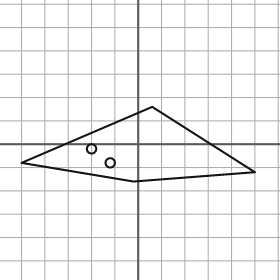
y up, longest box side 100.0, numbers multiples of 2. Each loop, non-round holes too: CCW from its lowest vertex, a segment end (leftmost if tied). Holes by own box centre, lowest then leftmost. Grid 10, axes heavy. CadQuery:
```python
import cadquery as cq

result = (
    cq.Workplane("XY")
    .moveTo(-2.0, -16.0)
    .lineTo(50.0, -12.0)
    .lineTo(6.0, 16.0)
    .lineTo(-50.0, -8.0)
    .close()
    .moveTo(-12.0, -8.0)
    .circle(2.0)
    .moveTo(-20.0, -2.0)
    .circle(2.0)
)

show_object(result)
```